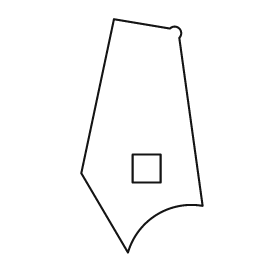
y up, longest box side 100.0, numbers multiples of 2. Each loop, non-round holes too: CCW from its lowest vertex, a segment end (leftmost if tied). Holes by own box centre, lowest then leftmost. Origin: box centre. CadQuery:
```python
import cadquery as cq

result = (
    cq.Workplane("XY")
    .moveTo(-6.0, -50.0)
    .threePointArc((6.0, -34.0), (26.0, -30.0))
    .lineTo(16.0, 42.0)
    .threePointArc((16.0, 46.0), (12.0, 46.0))
    .lineTo(-12.0, 50.0)
    .lineTo(-26.0, -16.0)
    .close()
    .moveTo(-4.0, -20.0)
    .lineTo(8.0, -20.0)
    .lineTo(8.0, -8.0)
    .lineTo(-4.0, -8.0)
    .close()
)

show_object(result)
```